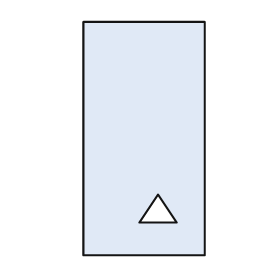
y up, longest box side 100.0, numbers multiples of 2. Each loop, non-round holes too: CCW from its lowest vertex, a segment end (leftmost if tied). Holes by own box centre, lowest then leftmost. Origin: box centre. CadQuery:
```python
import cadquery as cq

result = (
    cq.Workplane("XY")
    .moveTo(-26.0, -50.0)
    .lineTo(26.0, -50.0)
    .lineTo(26.0, 50.0)
    .lineTo(-26.0, 50.0)
    .close()
    .moveTo(-2.0, -36.0)
    .lineTo(14.0, -36.0)
    .lineTo(6.0, -24.0)
    .close()
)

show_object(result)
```